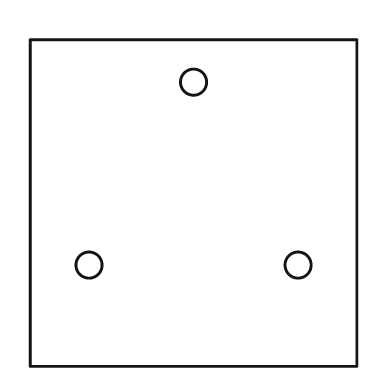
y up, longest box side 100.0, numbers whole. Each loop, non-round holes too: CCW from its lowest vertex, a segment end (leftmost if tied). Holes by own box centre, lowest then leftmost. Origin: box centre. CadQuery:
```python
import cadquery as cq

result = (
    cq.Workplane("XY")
    .moveTo(-50.0, -50.0)
    .lineTo(50.0, -50.0)
    .lineTo(50.0, 50.0)
    .lineTo(-50.0, 50.0)
    .close()
    .moveTo(-32.0, -19.0)
    .circle(4.0)
    .moveTo(32.0, -19.0)
    .circle(4.0)
    .moveTo(0.0, 37.0)
    .circle(4.0)
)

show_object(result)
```